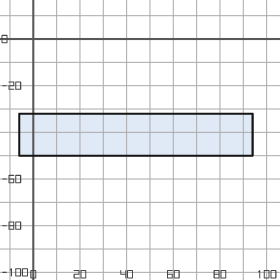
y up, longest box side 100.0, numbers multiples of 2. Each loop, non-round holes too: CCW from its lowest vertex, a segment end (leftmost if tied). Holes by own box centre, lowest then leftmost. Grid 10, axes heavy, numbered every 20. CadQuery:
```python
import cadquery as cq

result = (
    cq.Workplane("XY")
    .moveTo(-6.0, -50.0)
    .lineTo(94.0, -50.0)
    .lineTo(94.0, -32.0)
    .lineTo(-6.0, -32.0)
    .close()
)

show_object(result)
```